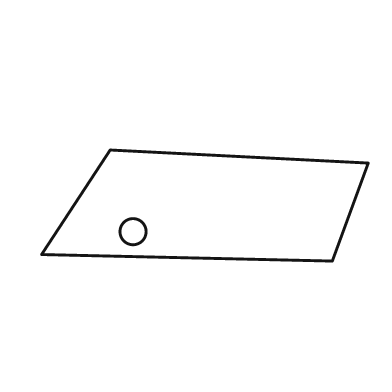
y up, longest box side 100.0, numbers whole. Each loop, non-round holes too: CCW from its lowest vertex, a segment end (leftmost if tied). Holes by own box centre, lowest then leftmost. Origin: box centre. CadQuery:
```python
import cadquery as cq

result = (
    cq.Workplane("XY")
    .moveTo(39.0, -17.0)
    .lineTo(50.0, 13.0)
    .lineTo(-29.0, 17.0)
    .lineTo(-50.0, -15.0)
    .close()
    .moveTo(-22.0, -8.0)
    .circle(4.0)
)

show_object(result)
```